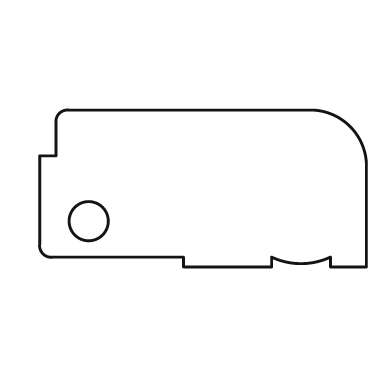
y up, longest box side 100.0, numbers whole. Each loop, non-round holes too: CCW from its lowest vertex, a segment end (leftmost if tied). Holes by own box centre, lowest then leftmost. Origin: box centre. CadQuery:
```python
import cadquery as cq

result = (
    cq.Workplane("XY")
    .moveTo(-6.0, -24.0)
    .lineTo(21.0, -24.0)
    .lineTo(21.0, -21.0)
    .threePointArc((30.0, -23.0), (39.0, -21.0))
    .lineTo(39.0, -24.0)
    .lineTo(50.0, -24.0)
    .lineTo(50.0, 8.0)
    .threePointArc((45.0, 19.0), (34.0, 24.0))
    .lineTo(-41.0, 24.0)
    .threePointArc((-44.0, 23.0), (-45.0, 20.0))
    .lineTo(-45.0, 10.0)
    .lineTo(-50.0, 10.0)
    .lineTo(-50.0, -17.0)
    .threePointArc((-49.0, -20.0), (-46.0, -21.0))
    .lineTo(-6.0, -21.0)
    .close()
    .moveTo(-35.0, -10.0)
    .circle(6.0)
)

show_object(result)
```